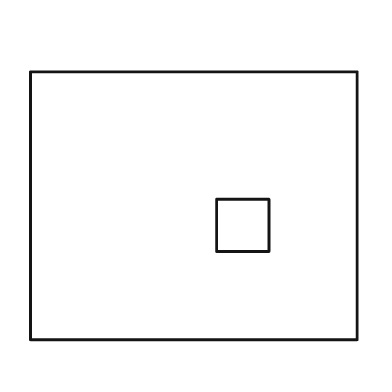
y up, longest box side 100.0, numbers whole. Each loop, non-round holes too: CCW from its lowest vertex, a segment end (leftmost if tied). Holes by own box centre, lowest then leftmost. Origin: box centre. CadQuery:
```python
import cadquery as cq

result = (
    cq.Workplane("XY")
    .moveTo(-50.0, -41.0)
    .lineTo(50.0, -41.0)
    .lineTo(50.0, 41.0)
    .lineTo(-50.0, 41.0)
    .close()
    .moveTo(7.0, -14.0)
    .lineTo(23.0, -14.0)
    .lineTo(23.0, 2.0)
    .lineTo(7.0, 2.0)
    .close()
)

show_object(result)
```